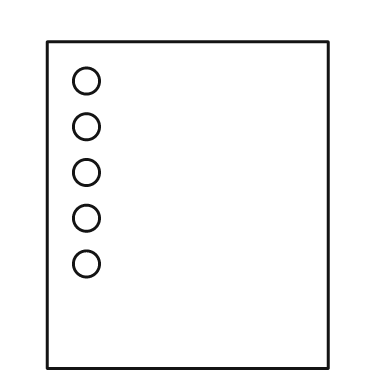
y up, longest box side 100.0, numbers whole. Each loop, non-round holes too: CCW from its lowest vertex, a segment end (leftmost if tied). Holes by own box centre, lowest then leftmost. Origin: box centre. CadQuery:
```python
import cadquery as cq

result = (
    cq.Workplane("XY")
    .moveTo(-43.0, -50.0)
    .lineTo(43.0, -50.0)
    .lineTo(43.0, 50.0)
    .lineTo(-43.0, 50.0)
    .close()
    .moveTo(-31.0, -18.0)
    .circle(4.0)
    .moveTo(-31.0, -4.0)
    .circle(4.0)
    .moveTo(-31.0, 10.0)
    .circle(4.0)
    .moveTo(-31.0, 24.0)
    .circle(4.0)
    .moveTo(-31.0, 38.0)
    .circle(4.0)
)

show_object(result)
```